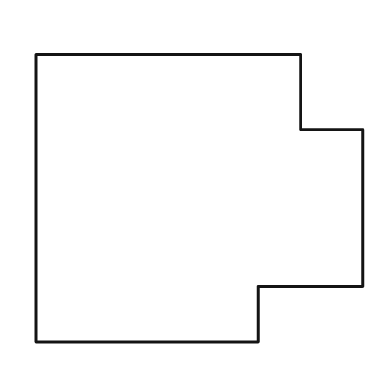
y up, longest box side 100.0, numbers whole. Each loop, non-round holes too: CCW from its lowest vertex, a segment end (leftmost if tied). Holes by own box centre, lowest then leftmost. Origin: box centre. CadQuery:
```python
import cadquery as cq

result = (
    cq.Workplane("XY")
    .moveTo(-50.0, -44.0)
    .lineTo(18.0, -44.0)
    .lineTo(18.0, -27.0)
    .lineTo(50.0, -27.0)
    .lineTo(50.0, 21.0)
    .lineTo(31.0, 21.0)
    .lineTo(31.0, 44.0)
    .lineTo(-50.0, 44.0)
    .close()
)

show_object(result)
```